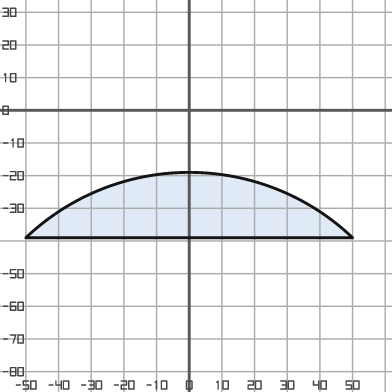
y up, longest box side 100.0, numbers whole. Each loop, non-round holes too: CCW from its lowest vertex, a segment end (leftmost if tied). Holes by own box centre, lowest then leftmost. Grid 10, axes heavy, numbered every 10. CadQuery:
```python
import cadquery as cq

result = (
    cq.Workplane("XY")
    .moveTo(-50.0, -39.0)
    .lineTo(50.0, -39.0)
    .threePointArc((0.0, -19.0), (-50.0, -39.0))
    .close()
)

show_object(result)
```